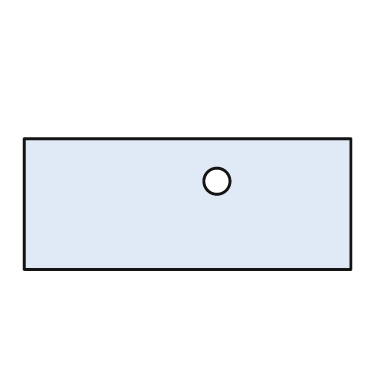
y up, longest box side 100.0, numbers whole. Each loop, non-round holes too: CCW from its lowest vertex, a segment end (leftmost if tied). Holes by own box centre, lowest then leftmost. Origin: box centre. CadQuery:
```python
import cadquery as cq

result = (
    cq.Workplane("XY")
    .moveTo(-50.0, -20.0)
    .lineTo(50.0, -20.0)
    .lineTo(50.0, 20.0)
    .lineTo(-50.0, 20.0)
    .close()
    .moveTo(9.0, 7.0)
    .circle(4.0)
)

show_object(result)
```